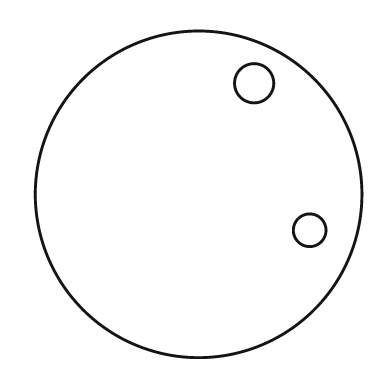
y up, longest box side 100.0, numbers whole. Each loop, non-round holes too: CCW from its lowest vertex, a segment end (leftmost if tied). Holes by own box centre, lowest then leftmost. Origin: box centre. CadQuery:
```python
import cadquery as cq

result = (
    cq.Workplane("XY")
    .moveTo(0.0, 0.0)
    .circle(50.0)
    .moveTo(34.0, -11.0)
    .circle(5.0)
    .moveTo(17.0, 34.0)
    .circle(6.0)
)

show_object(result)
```